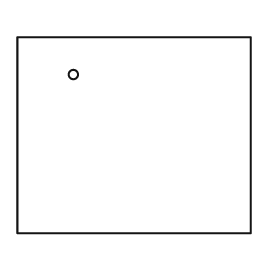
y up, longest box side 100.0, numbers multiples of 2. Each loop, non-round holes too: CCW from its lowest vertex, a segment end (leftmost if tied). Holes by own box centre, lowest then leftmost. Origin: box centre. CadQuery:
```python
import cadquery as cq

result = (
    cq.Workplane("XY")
    .moveTo(-50.0, -42.0)
    .lineTo(50.0, -42.0)
    .lineTo(50.0, 42.0)
    .lineTo(-50.0, 42.0)
    .close()
    .moveTo(-26.0, 26.0)
    .circle(2.0)
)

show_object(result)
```